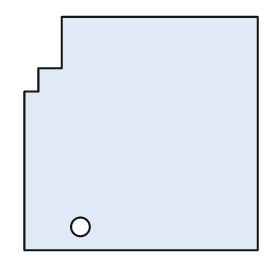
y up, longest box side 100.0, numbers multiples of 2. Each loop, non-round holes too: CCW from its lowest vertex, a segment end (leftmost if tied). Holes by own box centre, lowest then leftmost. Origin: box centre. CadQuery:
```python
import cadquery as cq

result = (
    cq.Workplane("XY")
    .moveTo(-50.0, -50.0)
    .lineTo(50.0, -50.0)
    .lineTo(50.0, 50.0)
    .lineTo(-34.0, 50.0)
    .lineTo(-34.0, 28.0)
    .lineTo(-44.0, 28.0)
    .lineTo(-44.0, 18.0)
    .lineTo(-50.0, 18.0)
    .close()
    .moveTo(-26.0, -40.0)
    .circle(4.0)
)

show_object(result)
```